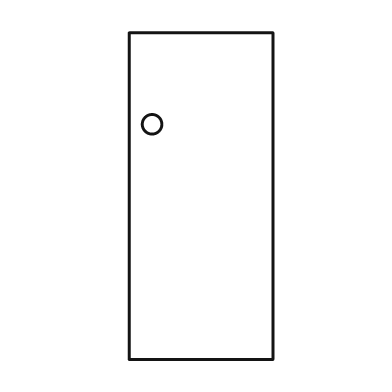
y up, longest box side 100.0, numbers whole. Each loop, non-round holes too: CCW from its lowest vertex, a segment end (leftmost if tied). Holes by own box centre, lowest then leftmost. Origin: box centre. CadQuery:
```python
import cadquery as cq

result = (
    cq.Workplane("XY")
    .moveTo(-22.0, -50.0)
    .lineTo(22.0, -50.0)
    .lineTo(22.0, 50.0)
    .lineTo(-22.0, 50.0)
    .close()
    .moveTo(-15.0, 22.0)
    .circle(3.0)
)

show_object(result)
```